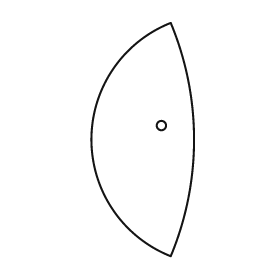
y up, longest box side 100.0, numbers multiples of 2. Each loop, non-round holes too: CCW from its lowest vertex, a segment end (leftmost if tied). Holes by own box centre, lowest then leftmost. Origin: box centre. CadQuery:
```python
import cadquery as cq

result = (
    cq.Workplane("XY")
    .moveTo(12.0, -50.0)
    .threePointArc((22.0, 0.0), (12.0, 50.0))
    .threePointArc((-22.0, 0.0), (12.0, -50.0))
    .close()
    .moveTo(8.0, 6.0)
    .circle(2.0)
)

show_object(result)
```